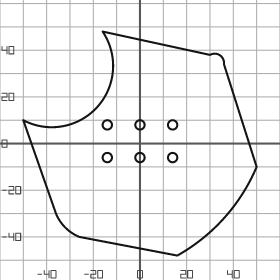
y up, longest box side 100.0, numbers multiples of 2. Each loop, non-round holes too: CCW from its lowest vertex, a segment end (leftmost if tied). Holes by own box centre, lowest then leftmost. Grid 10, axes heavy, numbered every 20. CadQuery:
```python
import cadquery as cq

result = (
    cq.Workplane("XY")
    .moveTo(16.0, -48.0)
    .threePointArc((36.0, -32.0), (50.0, -10.0))
    .lineTo(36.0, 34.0)
    .threePointArc((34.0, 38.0), (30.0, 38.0))
    .lineTo(-16.0, 48.0)
    .threePointArc((-18.0, 16.0), (-50.0, 10.0))
    .lineTo(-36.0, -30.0)
    .threePointArc((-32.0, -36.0), (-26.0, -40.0))
    .close()
    .moveTo(-14.0, -6.0)
    .circle(2.0)
    .moveTo(0.0, -6.0)
    .circle(2.0)
    .moveTo(14.0, -6.0)
    .circle(2.0)
    .moveTo(-14.0, 8.0)
    .circle(2.0)
    .moveTo(0.0, 8.0)
    .circle(2.0)
    .moveTo(14.0, 8.0)
    .circle(2.0)
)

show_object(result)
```